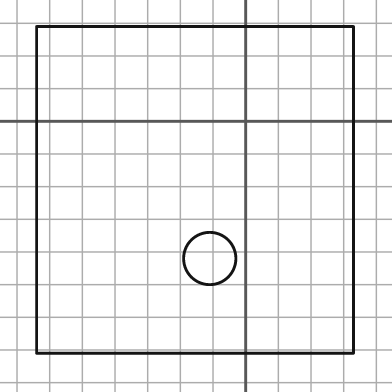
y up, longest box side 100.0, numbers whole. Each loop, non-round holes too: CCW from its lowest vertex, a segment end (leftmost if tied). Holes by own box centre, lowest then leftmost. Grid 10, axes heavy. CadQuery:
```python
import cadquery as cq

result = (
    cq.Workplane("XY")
    .moveTo(-64.0, -71.0)
    .lineTo(33.0, -71.0)
    .lineTo(33.0, 29.0)
    .lineTo(-64.0, 29.0)
    .close()
    .moveTo(-11.0, -42.0)
    .circle(8.0)
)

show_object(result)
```